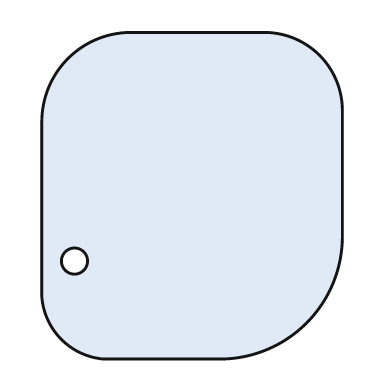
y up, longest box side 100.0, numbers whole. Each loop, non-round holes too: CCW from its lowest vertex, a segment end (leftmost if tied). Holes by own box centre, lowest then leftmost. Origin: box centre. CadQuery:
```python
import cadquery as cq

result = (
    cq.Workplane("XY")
    .moveTo(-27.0, -50.0)
    .lineTo(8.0, -50.0)
    .threePointArc((35.0, -39.0), (46.0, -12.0))
    .lineTo(46.0, 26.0)
    .threePointArc((39.0, 43.0), (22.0, 50.0))
    .lineTo(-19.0, 50.0)
    .threePointArc((-38.0, 42.0), (-46.0, 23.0))
    .lineTo(-46.0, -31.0)
    .threePointArc((-40.0, -44.0), (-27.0, -50.0))
    .close()
    .moveTo(-36.0, -20.0)
    .circle(4.0)
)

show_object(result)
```